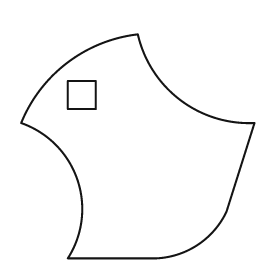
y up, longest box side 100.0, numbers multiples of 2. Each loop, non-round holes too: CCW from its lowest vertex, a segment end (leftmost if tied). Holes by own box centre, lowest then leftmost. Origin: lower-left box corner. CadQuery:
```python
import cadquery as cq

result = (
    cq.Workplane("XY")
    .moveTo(20.0, 0.0)
    .lineTo(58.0, 0.0)
    .threePointArc((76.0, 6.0), (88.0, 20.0))
    .lineTo(100.0, 58.0)
    .threePointArc((68.0, 68.0), (50.0, 96.0))
    .threePointArc((20.0, 84.0), (0.0, 58.0))
    .threePointArc((24.0, 34.0), (20.0, 0.0))
    .close()
    .moveTo(20.0, 64.0)
    .lineTo(32.0, 64.0)
    .lineTo(32.0, 76.0)
    .lineTo(20.0, 76.0)
    .close()
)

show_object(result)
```